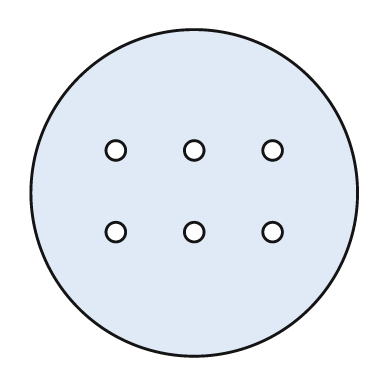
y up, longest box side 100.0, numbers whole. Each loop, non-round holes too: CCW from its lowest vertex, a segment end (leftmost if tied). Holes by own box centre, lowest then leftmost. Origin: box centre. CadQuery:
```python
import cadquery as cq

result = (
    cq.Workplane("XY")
    .moveTo(0.0, 0.0)
    .circle(50.0)
    .moveTo(-24.0, -12.0)
    .circle(3.0)
    .moveTo(0.0, -12.0)
    .circle(3.0)
    .moveTo(24.0, -12.0)
    .circle(3.0)
    .moveTo(-24.0, 13.0)
    .circle(3.0)
    .moveTo(0.0, 13.0)
    .circle(3.0)
    .moveTo(24.0, 13.0)
    .circle(3.0)
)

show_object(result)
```